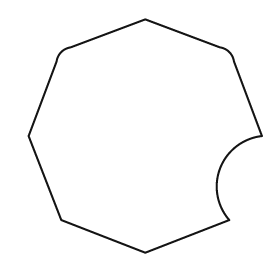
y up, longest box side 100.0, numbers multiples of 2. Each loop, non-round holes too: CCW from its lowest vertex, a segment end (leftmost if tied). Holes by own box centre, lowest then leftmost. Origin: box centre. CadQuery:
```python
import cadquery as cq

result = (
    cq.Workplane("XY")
    .moveTo(0.0, -50.0)
    .lineTo(36.0, -36.0)
    .threePointArc((32.0, -14.0), (50.0, 0.0))
    .lineTo(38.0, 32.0)
    .threePointArc((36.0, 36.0), (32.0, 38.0))
    .lineTo(0.0, 50.0)
    .lineTo(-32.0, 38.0)
    .threePointArc((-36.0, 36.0), (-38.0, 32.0))
    .lineTo(-50.0, 0.0)
    .lineTo(-36.0, -36.0)
    .close()
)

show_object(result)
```